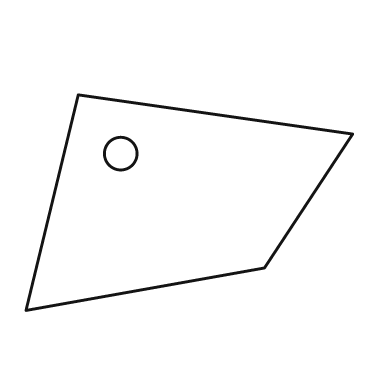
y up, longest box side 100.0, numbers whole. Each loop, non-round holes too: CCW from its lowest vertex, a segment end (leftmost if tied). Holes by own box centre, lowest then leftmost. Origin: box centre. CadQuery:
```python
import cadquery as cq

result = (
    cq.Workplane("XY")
    .moveTo(-50.0, -33.0)
    .lineTo(23.0, -20.0)
    .lineTo(50.0, 21.0)
    .lineTo(-34.0, 33.0)
    .close()
    .moveTo(-21.0, 15.0)
    .circle(5.0)
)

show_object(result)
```